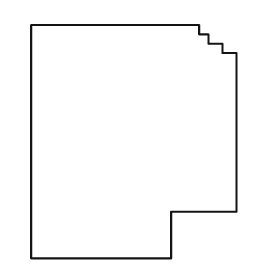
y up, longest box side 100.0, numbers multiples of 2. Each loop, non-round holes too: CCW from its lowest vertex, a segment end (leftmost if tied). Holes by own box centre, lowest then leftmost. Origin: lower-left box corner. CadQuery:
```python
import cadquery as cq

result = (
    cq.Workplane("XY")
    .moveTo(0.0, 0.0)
    .lineTo(60.0, 0.0)
    .lineTo(60.0, 20.0)
    .lineTo(88.0, 20.0)
    .lineTo(88.0, 88.0)
    .lineTo(82.0, 88.0)
    .lineTo(82.0, 92.0)
    .lineTo(76.0, 92.0)
    .lineTo(76.0, 96.0)
    .lineTo(72.0, 96.0)
    .lineTo(72.0, 100.0)
    .lineTo(0.0, 100.0)
    .close()
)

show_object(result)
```